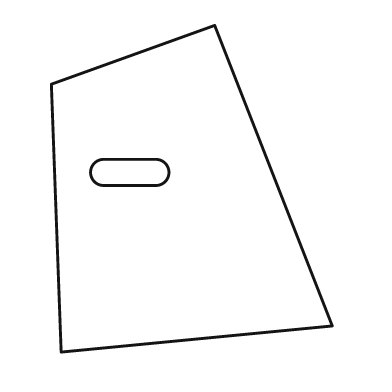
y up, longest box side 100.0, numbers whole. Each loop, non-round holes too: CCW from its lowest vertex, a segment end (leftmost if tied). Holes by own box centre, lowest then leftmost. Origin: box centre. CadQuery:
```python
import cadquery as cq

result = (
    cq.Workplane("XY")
    .moveTo(-40.0, -50.0)
    .lineTo(43.0, -42.0)
    .lineTo(7.0, 50.0)
    .lineTo(-43.0, 32.0)
    .close()
    .moveTo(-27.0, 1.0)
    .lineTo(-11.0, 1.0)
    .threePointArc((-7.0, 5.0), (-11.0, 9.0))
    .lineTo(-27.0, 9.0)
    .threePointArc((-31.0, 5.0), (-27.0, 1.0))
    .close()
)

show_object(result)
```